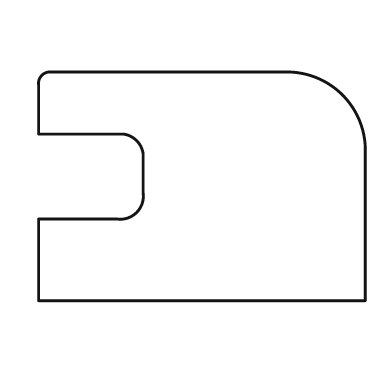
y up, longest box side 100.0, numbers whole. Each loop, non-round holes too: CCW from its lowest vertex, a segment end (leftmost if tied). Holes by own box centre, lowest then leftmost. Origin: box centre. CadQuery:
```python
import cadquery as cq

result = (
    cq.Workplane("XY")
    .moveTo(-50.0, -35.0)
    .lineTo(50.0, -35.0)
    .lineTo(50.0, 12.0)
    .threePointArc((43.0, 28.0), (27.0, 35.0))
    .lineTo(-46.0, 35.0)
    .threePointArc((-49.0, 34.0), (-50.0, 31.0))
    .lineTo(-50.0, 16.0)
    .lineTo(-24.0, 16.0)
    .threePointArc((-20.0, 14.0), (-18.0, 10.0))
    .lineTo(-18.0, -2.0)
    .threePointArc((-20.0, -8.0), (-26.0, -10.0))
    .lineTo(-50.0, -10.0)
    .close()
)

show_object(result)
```